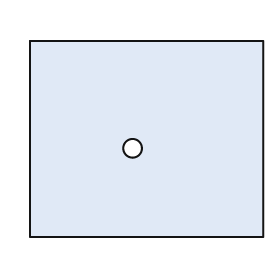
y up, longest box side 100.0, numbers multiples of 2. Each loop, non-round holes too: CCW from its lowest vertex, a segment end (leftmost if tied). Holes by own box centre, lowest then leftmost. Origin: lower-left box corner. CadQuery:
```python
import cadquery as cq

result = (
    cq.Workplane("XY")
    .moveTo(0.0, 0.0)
    .lineTo(100.0, 0.0)
    .lineTo(100.0, 84.0)
    .lineTo(0.0, 84.0)
    .close()
    .moveTo(44.0, 38.0)
    .circle(4.0)
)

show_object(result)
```